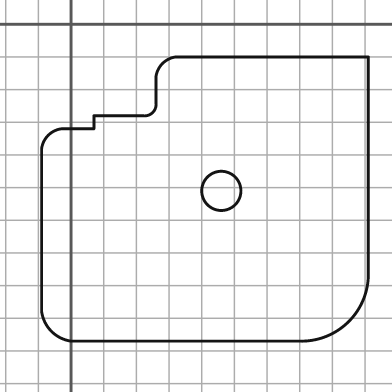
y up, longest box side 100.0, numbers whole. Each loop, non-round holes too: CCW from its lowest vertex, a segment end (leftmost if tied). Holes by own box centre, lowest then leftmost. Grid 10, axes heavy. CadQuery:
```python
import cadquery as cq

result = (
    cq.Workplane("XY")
    .moveTo(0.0, -97.0)
    .lineTo(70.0, -97.0)
    .threePointArc((85.0, -91.0), (91.0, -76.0))
    .lineTo(91.0, -10.0)
    .lineTo(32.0, -10.0)
    .threePointArc((28.0, -12.0), (26.0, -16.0))
    .lineTo(26.0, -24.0)
    .threePointArc((25.0, -27.0), (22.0, -28.0))
    .lineTo(7.0, -28.0)
    .lineTo(7.0, -32.0)
    .lineTo(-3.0, -32.0)
    .threePointArc((-7.0, -34.0), (-9.0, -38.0))
    .lineTo(-9.0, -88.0)
    .threePointArc((-6.0, -94.0), (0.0, -97.0))
    .close()
    .moveTo(46.0, -51.0)
    .circle(6.0)
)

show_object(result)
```